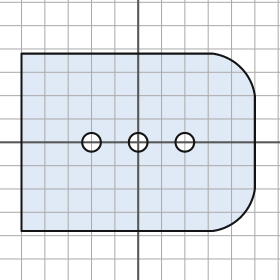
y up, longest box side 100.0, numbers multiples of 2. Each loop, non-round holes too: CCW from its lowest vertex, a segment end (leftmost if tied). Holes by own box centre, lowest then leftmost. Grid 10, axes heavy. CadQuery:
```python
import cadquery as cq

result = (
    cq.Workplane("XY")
    .moveTo(-50.0, -38.0)
    .lineTo(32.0, -38.0)
    .threePointArc((44.0, -32.0), (50.0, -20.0))
    .lineTo(50.0, 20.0)
    .threePointArc((44.0, 32.0), (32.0, 38.0))
    .lineTo(-50.0, 38.0)
    .close()
    .moveTo(-20.0, 0.0)
    .circle(4.0)
    .moveTo(0.0, 0.0)
    .circle(4.0)
    .moveTo(20.0, 0.0)
    .circle(4.0)
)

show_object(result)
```